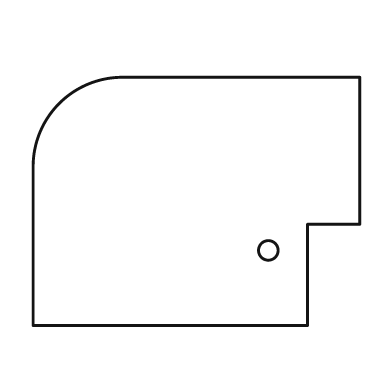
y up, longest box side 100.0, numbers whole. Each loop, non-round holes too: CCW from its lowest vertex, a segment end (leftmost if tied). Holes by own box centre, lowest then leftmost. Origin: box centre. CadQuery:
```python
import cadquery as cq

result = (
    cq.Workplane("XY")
    .moveTo(-50.0, -38.0)
    .lineTo(34.0, -38.0)
    .lineTo(34.0, -7.0)
    .lineTo(50.0, -7.0)
    .lineTo(50.0, 38.0)
    .lineTo(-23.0, 38.0)
    .threePointArc((-42.0, 30.0), (-50.0, 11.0))
    .close()
    .moveTo(22.0, -15.0)
    .circle(3.0)
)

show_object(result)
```